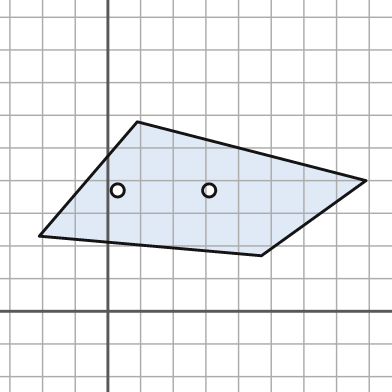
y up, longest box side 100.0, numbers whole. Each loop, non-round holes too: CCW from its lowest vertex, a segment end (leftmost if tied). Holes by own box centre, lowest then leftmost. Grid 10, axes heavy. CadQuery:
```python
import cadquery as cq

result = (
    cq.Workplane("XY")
    .moveTo(47.0, 17.0)
    .lineTo(79.0, 40.0)
    .lineTo(9.0, 58.0)
    .lineTo(-21.0, 23.0)
    .close()
    .moveTo(3.0, 37.0)
    .circle(2.0)
    .moveTo(31.0, 37.0)
    .circle(2.0)
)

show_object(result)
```